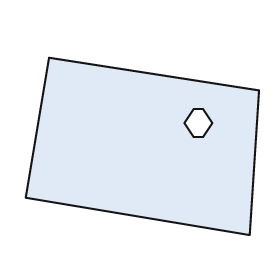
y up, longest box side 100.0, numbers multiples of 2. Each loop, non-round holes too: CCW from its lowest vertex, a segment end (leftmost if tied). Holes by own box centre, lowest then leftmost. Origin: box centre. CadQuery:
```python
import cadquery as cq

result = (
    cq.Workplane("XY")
    .moveTo(46.0, -38.0)
    .lineTo(50.0, 24.0)
    .lineTo(-40.0, 38.0)
    .lineTo(-50.0, -22.0)
    .close()
    .moveTo(22.0, 4.0)
    .lineTo(26.0, 4.0)
    .lineTo(30.0, 10.0)
    .lineTo(26.0, 16.0)
    .lineTo(22.0, 16.0)
    .lineTo(18.0, 10.0)
    .close()
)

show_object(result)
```